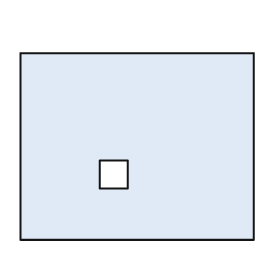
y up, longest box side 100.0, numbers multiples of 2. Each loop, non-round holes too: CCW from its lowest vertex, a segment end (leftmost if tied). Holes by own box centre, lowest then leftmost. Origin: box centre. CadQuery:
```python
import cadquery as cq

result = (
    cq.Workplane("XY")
    .moveTo(-50.0, -40.0)
    .lineTo(50.0, -40.0)
    .lineTo(50.0, 40.0)
    .lineTo(-50.0, 40.0)
    .close()
    .moveTo(-16.0, -18.0)
    .lineTo(-4.0, -18.0)
    .lineTo(-4.0, -6.0)
    .lineTo(-16.0, -6.0)
    .close()
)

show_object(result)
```